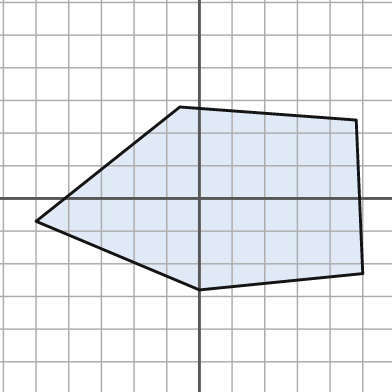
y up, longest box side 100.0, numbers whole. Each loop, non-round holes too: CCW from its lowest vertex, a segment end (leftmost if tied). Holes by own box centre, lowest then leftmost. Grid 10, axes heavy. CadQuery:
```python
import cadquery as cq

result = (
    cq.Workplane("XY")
    .moveTo(0.0, -28.0)
    .lineTo(50.0, -23.0)
    .lineTo(48.0, 24.0)
    .lineTo(-6.0, 28.0)
    .lineTo(-50.0, -7.0)
    .close()
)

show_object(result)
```